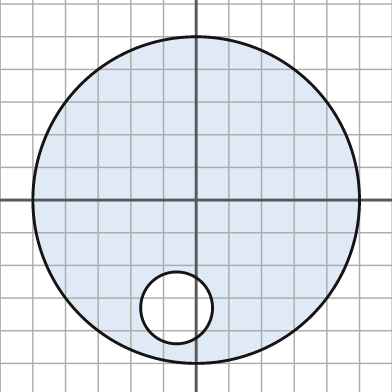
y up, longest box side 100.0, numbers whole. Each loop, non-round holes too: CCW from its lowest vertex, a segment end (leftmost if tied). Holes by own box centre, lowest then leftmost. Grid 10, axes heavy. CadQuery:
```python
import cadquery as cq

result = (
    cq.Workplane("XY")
    .moveTo(0.0, 0.0)
    .circle(50.0)
    .moveTo(-6.0, -33.0)
    .circle(11.0)
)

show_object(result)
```